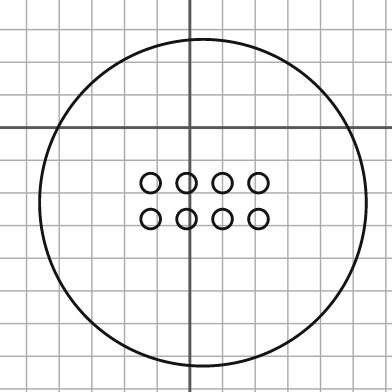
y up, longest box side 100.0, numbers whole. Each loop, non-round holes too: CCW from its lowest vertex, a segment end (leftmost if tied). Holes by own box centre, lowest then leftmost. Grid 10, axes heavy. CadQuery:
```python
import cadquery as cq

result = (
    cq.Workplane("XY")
    .moveTo(4.0, -23.0)
    .circle(50.0)
    .moveTo(-12.0, -28.0)
    .circle(3.0)
    .moveTo(-1.0, -28.0)
    .circle(3.0)
    .moveTo(10.0, -28.0)
    .circle(3.0)
    .moveTo(21.0, -28.0)
    .circle(3.0)
    .moveTo(-12.0, -17.0)
    .circle(3.0)
    .moveTo(-1.0, -17.0)
    .circle(3.0)
    .moveTo(10.0, -17.0)
    .circle(3.0)
    .moveTo(21.0, -17.0)
    .circle(3.0)
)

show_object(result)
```